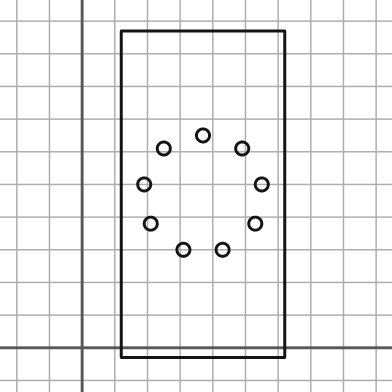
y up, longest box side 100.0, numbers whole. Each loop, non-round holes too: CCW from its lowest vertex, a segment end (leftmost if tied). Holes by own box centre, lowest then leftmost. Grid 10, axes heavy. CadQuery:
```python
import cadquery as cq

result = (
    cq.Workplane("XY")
    .moveTo(12.0, -3.0)
    .lineTo(62.0, -3.0)
    .lineTo(62.0, 97.0)
    .lineTo(12.0, 97.0)
    .close()
    .moveTo(31.0, 30.0)
    .circle(2.0)
    .moveTo(43.0, 30.0)
    .circle(2.0)
    .moveTo(21.0, 38.0)
    .circle(2.0)
    .moveTo(53.0, 38.0)
    .circle(2.0)
    .moveTo(19.0, 50.0)
    .circle(2.0)
    .moveTo(55.0, 50.0)
    .circle(2.0)
    .moveTo(25.0, 61.0)
    .circle(2.0)
    .moveTo(49.0, 61.0)
    .circle(2.0)
    .moveTo(37.0, 65.0)
    .circle(2.0)
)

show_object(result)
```